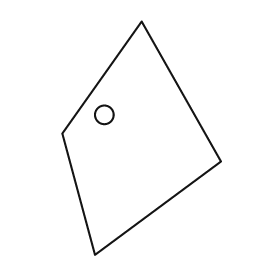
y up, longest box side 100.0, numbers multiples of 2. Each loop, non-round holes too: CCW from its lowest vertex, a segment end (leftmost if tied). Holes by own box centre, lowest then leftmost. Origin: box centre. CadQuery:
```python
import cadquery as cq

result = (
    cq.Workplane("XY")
    .moveTo(-20.0, -50.0)
    .lineTo(34.0, -10.0)
    .lineTo(0.0, 50.0)
    .lineTo(-34.0, 2.0)
    .close()
    .moveTo(-16.0, 10.0)
    .circle(4.0)
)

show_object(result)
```